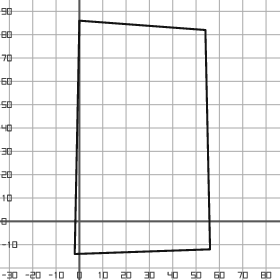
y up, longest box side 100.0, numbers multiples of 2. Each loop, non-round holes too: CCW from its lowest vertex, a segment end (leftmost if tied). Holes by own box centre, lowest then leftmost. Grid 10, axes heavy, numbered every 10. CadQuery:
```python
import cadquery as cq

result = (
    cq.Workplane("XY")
    .moveTo(-2.0, -14.0)
    .lineTo(56.0, -12.0)
    .lineTo(54.0, 82.0)
    .lineTo(0.0, 86.0)
    .close()
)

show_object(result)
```